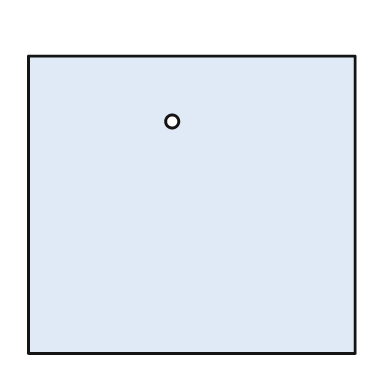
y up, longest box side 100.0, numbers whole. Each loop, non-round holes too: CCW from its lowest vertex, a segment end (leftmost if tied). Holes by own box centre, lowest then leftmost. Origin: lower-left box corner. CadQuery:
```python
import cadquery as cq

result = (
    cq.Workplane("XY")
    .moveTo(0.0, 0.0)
    .lineTo(100.0, 0.0)
    .lineTo(100.0, 91.0)
    .lineTo(0.0, 91.0)
    .close()
    .moveTo(44.0, 71.0)
    .circle(2.0)
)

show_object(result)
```